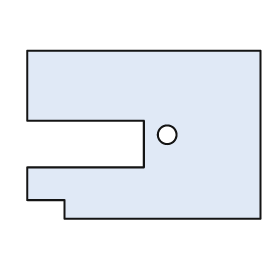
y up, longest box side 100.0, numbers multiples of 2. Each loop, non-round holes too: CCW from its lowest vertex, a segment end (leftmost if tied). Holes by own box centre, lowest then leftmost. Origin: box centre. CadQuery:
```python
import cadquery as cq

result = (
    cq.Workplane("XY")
    .moveTo(-34.0, -36.0)
    .lineTo(50.0, -36.0)
    .lineTo(50.0, 36.0)
    .lineTo(-50.0, 36.0)
    .lineTo(-50.0, 6.0)
    .lineTo(0.0, 6.0)
    .lineTo(0.0, -14.0)
    .lineTo(-50.0, -14.0)
    .lineTo(-50.0, -28.0)
    .lineTo(-34.0, -28.0)
    .close()
    .moveTo(10.0, 0.0)
    .circle(4.0)
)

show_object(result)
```